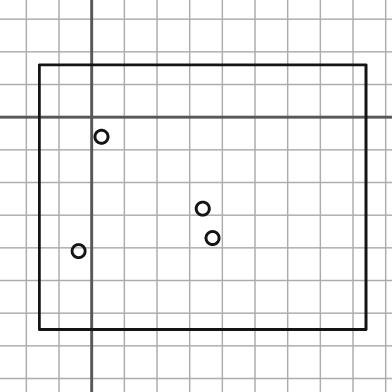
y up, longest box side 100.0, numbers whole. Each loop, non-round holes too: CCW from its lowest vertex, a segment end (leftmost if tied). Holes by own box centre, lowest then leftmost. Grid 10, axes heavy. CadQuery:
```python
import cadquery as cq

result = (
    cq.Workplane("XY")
    .moveTo(-16.0, -65.0)
    .lineTo(84.0, -65.0)
    .lineTo(84.0, 16.0)
    .lineTo(-16.0, 16.0)
    .close()
    .moveTo(-4.0, -41.0)
    .circle(2.0)
    .moveTo(37.0, -37.0)
    .circle(2.0)
    .moveTo(34.0, -28.0)
    .circle(2.0)
    .moveTo(3.0, -6.0)
    .circle(2.0)
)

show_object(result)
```